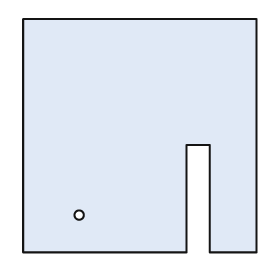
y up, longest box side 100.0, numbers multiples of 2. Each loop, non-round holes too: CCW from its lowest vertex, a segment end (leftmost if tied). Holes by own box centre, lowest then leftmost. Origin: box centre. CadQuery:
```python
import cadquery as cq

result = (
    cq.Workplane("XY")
    .moveTo(-50.0, -50.0)
    .lineTo(20.0, -50.0)
    .lineTo(20.0, -4.0)
    .lineTo(30.0, -4.0)
    .lineTo(30.0, -50.0)
    .lineTo(50.0, -50.0)
    .lineTo(50.0, 50.0)
    .lineTo(-50.0, 50.0)
    .close()
    .moveTo(-26.0, -34.0)
    .circle(2.0)
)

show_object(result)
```